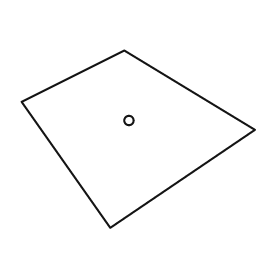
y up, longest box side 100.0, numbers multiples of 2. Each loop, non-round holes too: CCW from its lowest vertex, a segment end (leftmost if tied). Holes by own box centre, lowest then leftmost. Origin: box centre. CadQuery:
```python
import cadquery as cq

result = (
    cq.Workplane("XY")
    .moveTo(-12.0, -38.0)
    .lineTo(50.0, 4.0)
    .lineTo(-6.0, 38.0)
    .lineTo(-50.0, 16.0)
    .close()
    .moveTo(-4.0, 8.0)
    .circle(2.0)
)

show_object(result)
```